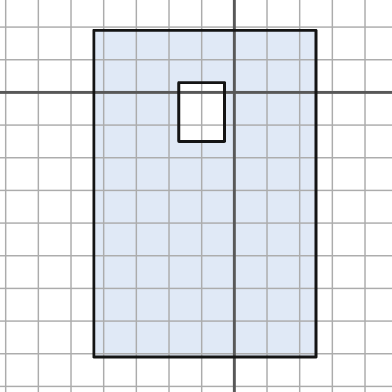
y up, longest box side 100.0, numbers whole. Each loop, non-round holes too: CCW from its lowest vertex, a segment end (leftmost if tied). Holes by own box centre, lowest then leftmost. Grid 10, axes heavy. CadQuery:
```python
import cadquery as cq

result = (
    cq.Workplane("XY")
    .moveTo(-43.0, -81.0)
    .lineTo(25.0, -81.0)
    .lineTo(25.0, 19.0)
    .lineTo(-43.0, 19.0)
    .close()
    .moveTo(-17.0, -15.0)
    .lineTo(-3.0, -15.0)
    .lineTo(-3.0, 3.0)
    .lineTo(-17.0, 3.0)
    .close()
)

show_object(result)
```